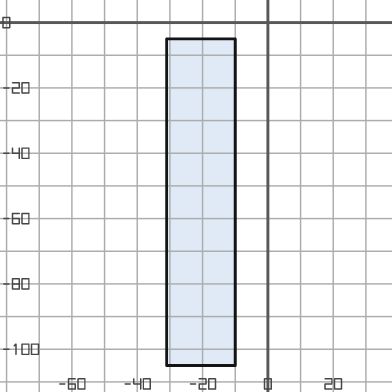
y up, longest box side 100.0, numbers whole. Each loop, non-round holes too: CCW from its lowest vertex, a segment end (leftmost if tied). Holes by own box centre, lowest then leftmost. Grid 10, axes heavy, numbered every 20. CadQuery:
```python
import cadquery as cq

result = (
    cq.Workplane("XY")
    .moveTo(-31.0, -105.0)
    .lineTo(-10.0, -105.0)
    .lineTo(-10.0, -5.0)
    .lineTo(-31.0, -5.0)
    .close()
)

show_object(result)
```